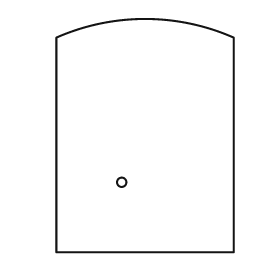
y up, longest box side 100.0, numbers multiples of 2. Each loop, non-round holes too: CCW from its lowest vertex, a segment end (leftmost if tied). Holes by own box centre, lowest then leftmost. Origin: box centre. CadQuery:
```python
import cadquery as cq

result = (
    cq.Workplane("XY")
    .moveTo(-38.0, -50.0)
    .lineTo(38.0, -50.0)
    .lineTo(38.0, 42.0)
    .threePointArc((0.0, 50.0), (-38.0, 42.0))
    .close()
    .moveTo(-10.0, -20.0)
    .circle(2.0)
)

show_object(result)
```